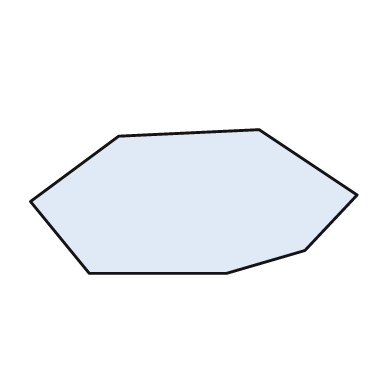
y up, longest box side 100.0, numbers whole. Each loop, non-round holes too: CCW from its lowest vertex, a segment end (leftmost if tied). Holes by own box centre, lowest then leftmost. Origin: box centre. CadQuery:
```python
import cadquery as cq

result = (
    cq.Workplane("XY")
    .moveTo(-32.0, -22.0)
    .lineTo(10.0, -22.0)
    .lineTo(34.0, -15.0)
    .lineTo(50.0, 2.0)
    .lineTo(20.0, 22.0)
    .lineTo(-23.0, 20.0)
    .lineTo(-50.0, 0.0)
    .close()
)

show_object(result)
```